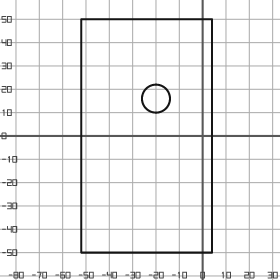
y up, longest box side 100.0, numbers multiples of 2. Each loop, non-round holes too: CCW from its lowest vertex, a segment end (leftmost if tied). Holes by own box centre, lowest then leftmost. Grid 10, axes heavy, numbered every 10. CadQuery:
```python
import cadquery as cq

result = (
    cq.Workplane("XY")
    .moveTo(-52.0, -50.0)
    .lineTo(4.0, -50.0)
    .lineTo(4.0, 50.0)
    .lineTo(-52.0, 50.0)
    .close()
    .moveTo(-20.0, 16.0)
    .circle(6.0)
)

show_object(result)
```